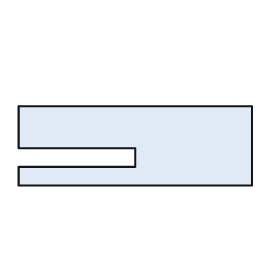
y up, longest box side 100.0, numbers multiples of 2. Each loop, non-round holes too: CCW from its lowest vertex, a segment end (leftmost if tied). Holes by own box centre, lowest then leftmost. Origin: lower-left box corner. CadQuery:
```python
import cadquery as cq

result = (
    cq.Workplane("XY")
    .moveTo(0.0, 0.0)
    .lineTo(100.0, 0.0)
    .lineTo(100.0, 34.0)
    .lineTo(0.0, 34.0)
    .lineTo(0.0, 16.0)
    .lineTo(50.0, 16.0)
    .lineTo(50.0, 8.0)
    .lineTo(0.0, 8.0)
    .close()
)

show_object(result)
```